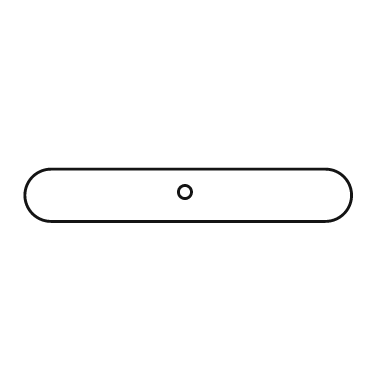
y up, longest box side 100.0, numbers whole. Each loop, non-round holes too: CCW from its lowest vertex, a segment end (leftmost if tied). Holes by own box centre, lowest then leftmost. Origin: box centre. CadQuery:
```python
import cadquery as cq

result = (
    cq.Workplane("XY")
    .moveTo(-42.0, -8.0)
    .lineTo(42.0, -8.0)
    .threePointArc((50.0, 0.0), (42.0, 8.0))
    .lineTo(-42.0, 8.0)
    .threePointArc((-50.0, 0.0), (-42.0, -8.0))
    .close()
    .moveTo(-1.0, 1.0)
    .circle(2.0)
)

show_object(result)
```